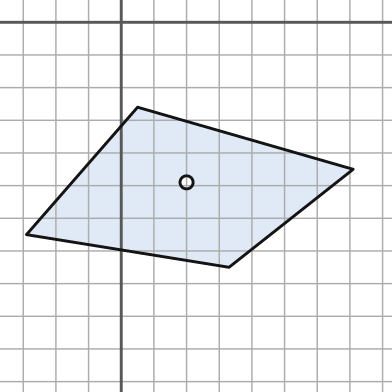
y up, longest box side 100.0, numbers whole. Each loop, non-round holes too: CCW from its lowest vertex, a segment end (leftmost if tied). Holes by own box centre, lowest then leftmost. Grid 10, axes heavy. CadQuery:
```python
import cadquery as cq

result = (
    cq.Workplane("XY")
    .moveTo(33.0, -75.0)
    .lineTo(71.0, -45.0)
    .lineTo(5.0, -26.0)
    .lineTo(-29.0, -65.0)
    .close()
    .moveTo(20.0, -49.0)
    .circle(2.0)
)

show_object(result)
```